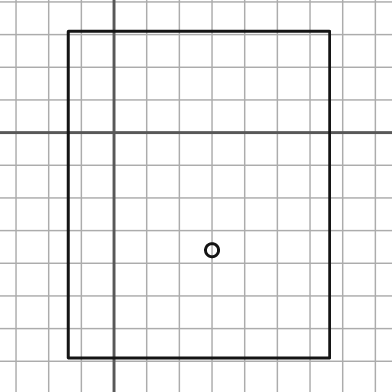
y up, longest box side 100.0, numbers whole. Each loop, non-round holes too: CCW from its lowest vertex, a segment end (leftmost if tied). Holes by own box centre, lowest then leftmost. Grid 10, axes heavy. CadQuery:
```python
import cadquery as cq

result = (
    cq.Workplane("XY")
    .moveTo(-14.0, -69.0)
    .lineTo(66.0, -69.0)
    .lineTo(66.0, 31.0)
    .lineTo(-14.0, 31.0)
    .close()
    .moveTo(30.0, -36.0)
    .circle(2.0)
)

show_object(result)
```